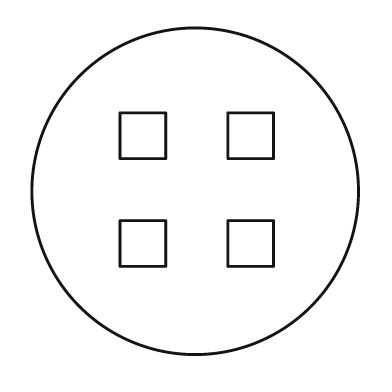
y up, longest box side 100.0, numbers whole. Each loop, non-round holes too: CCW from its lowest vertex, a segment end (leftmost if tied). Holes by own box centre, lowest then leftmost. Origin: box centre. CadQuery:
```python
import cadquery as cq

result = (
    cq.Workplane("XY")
    .moveTo(0.0, 0.0)
    .circle(50.0)
    .moveTo(-23.0, -23.0)
    .lineTo(-9.0, -23.0)
    .lineTo(-9.0, -9.0)
    .lineTo(-23.0, -9.0)
    .close()
    .moveTo(10.0, -23.0)
    .lineTo(24.0, -23.0)
    .lineTo(24.0, -9.0)
    .lineTo(10.0, -9.0)
    .close()
    .moveTo(-23.0, 10.0)
    .lineTo(-9.0, 10.0)
    .lineTo(-9.0, 24.0)
    .lineTo(-23.0, 24.0)
    .close()
    .moveTo(10.0, 10.0)
    .lineTo(24.0, 10.0)
    .lineTo(24.0, 24.0)
    .lineTo(10.0, 24.0)
    .close()
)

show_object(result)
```